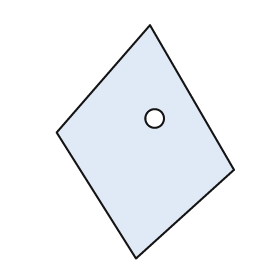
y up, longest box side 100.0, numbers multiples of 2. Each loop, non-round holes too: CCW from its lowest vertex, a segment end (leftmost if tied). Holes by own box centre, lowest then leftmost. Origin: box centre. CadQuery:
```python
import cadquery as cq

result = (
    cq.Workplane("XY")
    .moveTo(-4.0, -50.0)
    .lineTo(38.0, -12.0)
    .lineTo(2.0, 50.0)
    .lineTo(-38.0, 4.0)
    .close()
    .moveTo(4.0, 10.0)
    .circle(4.0)
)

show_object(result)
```